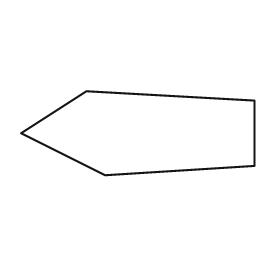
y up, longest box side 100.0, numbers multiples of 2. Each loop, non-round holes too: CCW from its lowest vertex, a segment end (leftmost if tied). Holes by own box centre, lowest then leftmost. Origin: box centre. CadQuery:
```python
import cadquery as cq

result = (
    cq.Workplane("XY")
    .moveTo(-14.0, -18.0)
    .lineTo(50.0, -14.0)
    .lineTo(50.0, 14.0)
    .lineTo(-22.0, 18.0)
    .lineTo(-50.0, 0.0)
    .close()
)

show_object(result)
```